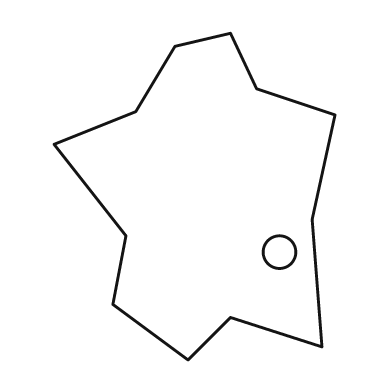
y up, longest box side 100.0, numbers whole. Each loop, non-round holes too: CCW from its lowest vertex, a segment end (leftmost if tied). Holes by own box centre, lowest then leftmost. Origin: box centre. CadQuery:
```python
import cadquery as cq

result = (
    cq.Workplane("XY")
    .moveTo(-2.0, -50.0)
    .lineTo(11.0, -37.0)
    .lineTo(39.0, -46.0)
    .lineTo(36.0, -7.0)
    .lineTo(43.0, 25.0)
    .lineTo(19.0, 33.0)
    .lineTo(11.0, 50.0)
    .lineTo(-6.0, 46.0)
    .lineTo(-18.0, 26.0)
    .lineTo(-43.0, 16.0)
    .lineTo(-21.0, -12.0)
    .lineTo(-25.0, -33.0)
    .close()
    .moveTo(26.0, -17.0)
    .circle(5.0)
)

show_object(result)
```